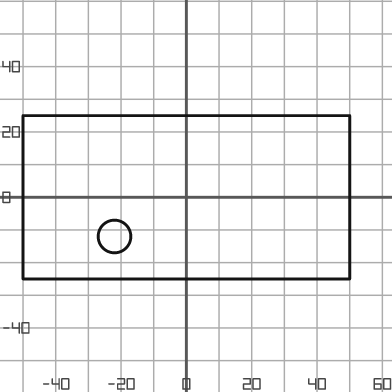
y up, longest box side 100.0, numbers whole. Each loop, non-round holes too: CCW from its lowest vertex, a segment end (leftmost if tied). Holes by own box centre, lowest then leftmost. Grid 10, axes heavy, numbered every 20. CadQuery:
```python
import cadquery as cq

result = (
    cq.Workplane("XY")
    .moveTo(-50.0, -25.0)
    .lineTo(50.0, -25.0)
    .lineTo(50.0, 25.0)
    .lineTo(-50.0, 25.0)
    .close()
    .moveTo(-22.0, -12.0)
    .circle(5.0)
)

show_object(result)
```